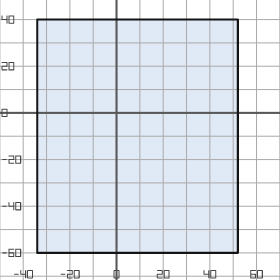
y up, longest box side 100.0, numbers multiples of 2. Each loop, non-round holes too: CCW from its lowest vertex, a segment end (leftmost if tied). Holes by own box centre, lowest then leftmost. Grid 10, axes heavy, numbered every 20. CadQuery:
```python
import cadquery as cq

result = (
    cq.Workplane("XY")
    .moveTo(-34.0, -60.0)
    .lineTo(52.0, -60.0)
    .lineTo(52.0, 40.0)
    .lineTo(-34.0, 40.0)
    .close()
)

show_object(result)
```